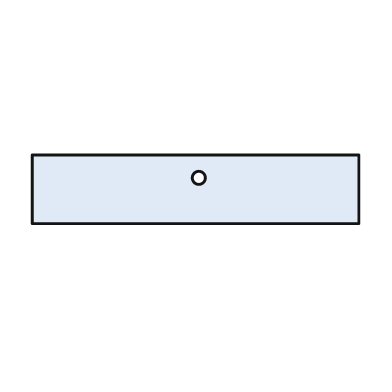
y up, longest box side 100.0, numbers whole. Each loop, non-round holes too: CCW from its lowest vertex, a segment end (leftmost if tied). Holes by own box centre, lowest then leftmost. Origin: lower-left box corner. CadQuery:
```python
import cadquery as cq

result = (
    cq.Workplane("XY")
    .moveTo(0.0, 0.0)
    .lineTo(100.0, 0.0)
    .lineTo(100.0, 21.0)
    .lineTo(0.0, 21.0)
    .close()
    .moveTo(51.0, 14.0)
    .circle(2.0)
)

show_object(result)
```